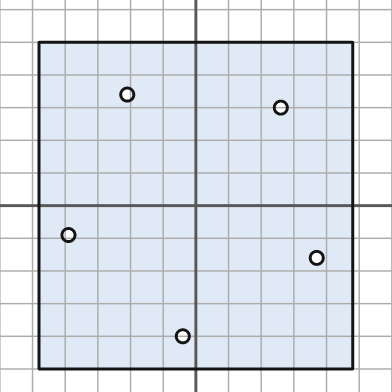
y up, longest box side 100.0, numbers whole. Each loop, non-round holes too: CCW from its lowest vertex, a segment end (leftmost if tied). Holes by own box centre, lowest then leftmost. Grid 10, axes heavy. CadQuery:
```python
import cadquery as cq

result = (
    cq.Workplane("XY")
    .moveTo(-48.0, -50.0)
    .lineTo(48.0, -50.0)
    .lineTo(48.0, 50.0)
    .lineTo(-48.0, 50.0)
    .close()
    .moveTo(-4.0, -40.0)
    .circle(2.0)
    .moveTo(37.0, -16.0)
    .circle(2.0)
    .moveTo(-39.0, -9.0)
    .circle(2.0)
    .moveTo(26.0, 30.0)
    .circle(2.0)
    .moveTo(-21.0, 34.0)
    .circle(2.0)
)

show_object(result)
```